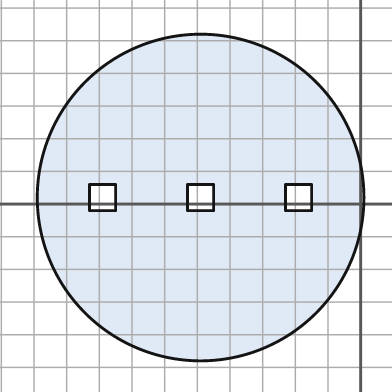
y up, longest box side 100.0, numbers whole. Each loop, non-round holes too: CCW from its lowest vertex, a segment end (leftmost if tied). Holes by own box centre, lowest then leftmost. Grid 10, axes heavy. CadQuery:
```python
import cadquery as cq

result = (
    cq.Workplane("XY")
    .moveTo(-49.0, 2.0)
    .circle(50.0)
    .moveTo(-83.0, -2.0)
    .lineTo(-75.0, -2.0)
    .lineTo(-75.0, 6.0)
    .lineTo(-83.0, 6.0)
    .close()
    .moveTo(-53.0, -2.0)
    .lineTo(-45.0, -2.0)
    .lineTo(-45.0, 6.0)
    .lineTo(-53.0, 6.0)
    .close()
    .moveTo(-23.0, -2.0)
    .lineTo(-15.0, -2.0)
    .lineTo(-15.0, 6.0)
    .lineTo(-23.0, 6.0)
    .close()
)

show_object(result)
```